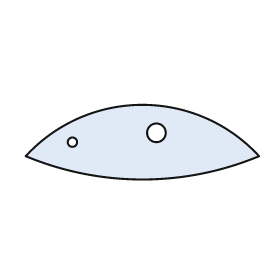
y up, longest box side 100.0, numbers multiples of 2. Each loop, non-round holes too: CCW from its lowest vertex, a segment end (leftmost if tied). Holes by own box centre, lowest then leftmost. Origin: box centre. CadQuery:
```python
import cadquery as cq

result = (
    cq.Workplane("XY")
    .moveTo(-50.0, -6.0)
    .threePointArc((0.0, -16.0), (50.0, -6.0))
    .threePointArc((0.0, 16.0), (-50.0, -6.0))
    .close()
    .moveTo(-30.0, 0.0)
    .circle(2.0)
    .moveTo(6.0, 4.0)
    .circle(4.0)
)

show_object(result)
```